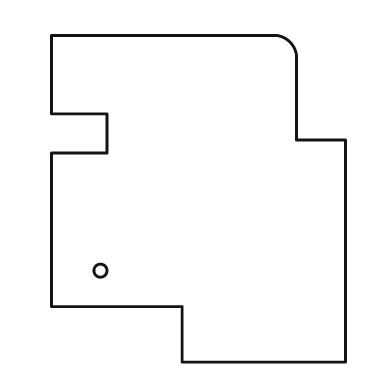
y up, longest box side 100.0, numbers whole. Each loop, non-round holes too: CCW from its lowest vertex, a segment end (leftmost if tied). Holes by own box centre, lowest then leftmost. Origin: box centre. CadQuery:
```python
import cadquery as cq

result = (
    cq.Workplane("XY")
    .moveTo(-5.0, -50.0)
    .lineTo(45.0, -50.0)
    .lineTo(45.0, 18.0)
    .lineTo(30.0, 18.0)
    .lineTo(30.0, 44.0)
    .threePointArc((28.0, 48.0), (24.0, 50.0))
    .lineTo(-45.0, 50.0)
    .lineTo(-45.0, 26.0)
    .lineTo(-28.0, 26.0)
    .lineTo(-28.0, 14.0)
    .lineTo(-45.0, 14.0)
    .lineTo(-45.0, -33.0)
    .lineTo(-5.0, -33.0)
    .close()
    .moveTo(-30.0, -22.0)
    .circle(2.0)
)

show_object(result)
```